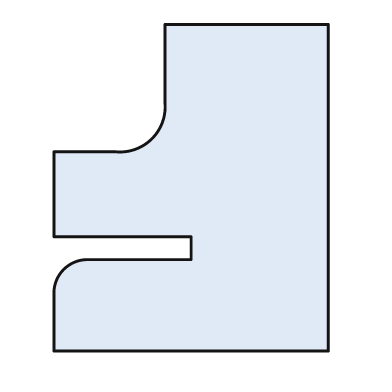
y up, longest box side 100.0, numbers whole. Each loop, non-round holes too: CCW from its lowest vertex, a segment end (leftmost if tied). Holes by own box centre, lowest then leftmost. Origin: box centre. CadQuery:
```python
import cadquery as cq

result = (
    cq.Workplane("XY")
    .moveTo(-42.0, -50.0)
    .lineTo(42.0, -50.0)
    .lineTo(42.0, 50.0)
    .lineTo(-8.0, 50.0)
    .lineTo(-8.0, 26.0)
    .threePointArc((-12.0, 15.0), (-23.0, 11.0))
    .lineTo(-42.0, 11.0)
    .lineTo(-42.0, -15.0)
    .lineTo(0.0, -15.0)
    .lineTo(0.0, -22.0)
    .lineTo(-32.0, -22.0)
    .threePointArc((-39.0, -25.0), (-42.0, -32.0))
    .close()
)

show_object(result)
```